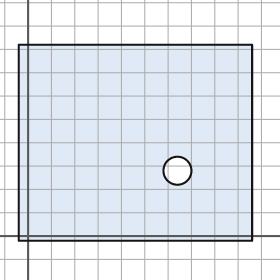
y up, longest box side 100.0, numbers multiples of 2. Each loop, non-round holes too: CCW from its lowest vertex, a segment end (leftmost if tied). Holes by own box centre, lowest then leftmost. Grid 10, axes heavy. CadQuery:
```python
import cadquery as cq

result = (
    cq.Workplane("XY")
    .moveTo(-4.0, -2.0)
    .lineTo(96.0, -2.0)
    .lineTo(96.0, 82.0)
    .lineTo(-4.0, 82.0)
    .close()
    .moveTo(64.0, 28.0)
    .circle(6.0)
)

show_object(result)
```